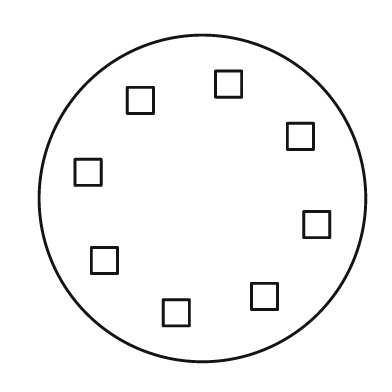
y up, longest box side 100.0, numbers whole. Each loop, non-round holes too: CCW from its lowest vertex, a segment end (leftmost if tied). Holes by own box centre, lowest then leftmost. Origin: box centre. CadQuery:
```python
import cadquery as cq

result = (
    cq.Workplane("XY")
    .moveTo(0.0, 0.0)
    .circle(50.0)
    .moveTo(-12.0, -39.0)
    .lineTo(-4.0, -39.0)
    .lineTo(-4.0, -31.0)
    .lineTo(-12.0, -31.0)
    .close()
    .moveTo(15.0, -34.0)
    .lineTo(23.0, -34.0)
    .lineTo(23.0, -26.0)
    .lineTo(15.0, -26.0)
    .close()
    .moveTo(-34.0, -23.0)
    .lineTo(-26.0, -23.0)
    .lineTo(-26.0, -15.0)
    .lineTo(-34.0, -15.0)
    .close()
    .moveTo(31.0, -12.0)
    .lineTo(39.0, -12.0)
    .lineTo(39.0, -4.0)
    .lineTo(31.0, -4.0)
    .close()
    .moveTo(-39.0, 4.0)
    .lineTo(-31.0, 4.0)
    .lineTo(-31.0, 12.0)
    .lineTo(-39.0, 12.0)
    .close()
    .moveTo(26.0, 15.0)
    .lineTo(34.0, 15.0)
    .lineTo(34.0, 23.0)
    .lineTo(26.0, 23.0)
    .close()
    .moveTo(-23.0, 26.0)
    .lineTo(-15.0, 26.0)
    .lineTo(-15.0, 34.0)
    .lineTo(-23.0, 34.0)
    .close()
    .moveTo(4.0, 31.0)
    .lineTo(12.0, 31.0)
    .lineTo(12.0, 39.0)
    .lineTo(4.0, 39.0)
    .close()
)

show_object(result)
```